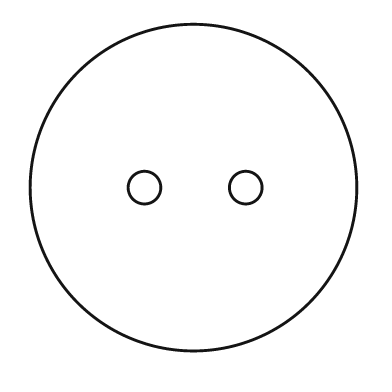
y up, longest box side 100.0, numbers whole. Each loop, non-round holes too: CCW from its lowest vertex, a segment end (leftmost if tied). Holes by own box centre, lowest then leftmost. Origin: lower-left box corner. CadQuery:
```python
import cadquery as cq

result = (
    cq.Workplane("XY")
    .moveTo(50.0, 50.0)
    .circle(50.0)
    .moveTo(35.0, 50.0)
    .circle(5.0)
    .moveTo(66.0, 50.0)
    .circle(5.0)
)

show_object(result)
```